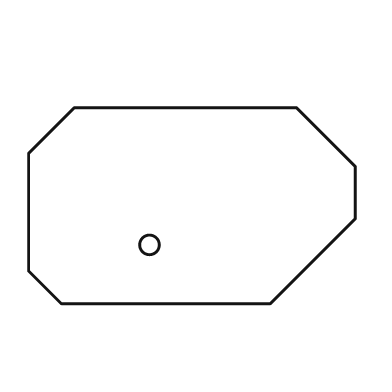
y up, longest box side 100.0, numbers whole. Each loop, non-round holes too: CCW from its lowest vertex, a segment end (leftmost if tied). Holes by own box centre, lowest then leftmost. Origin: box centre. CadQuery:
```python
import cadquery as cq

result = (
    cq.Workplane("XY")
    .moveTo(-40.0, -30.0)
    .lineTo(24.0, -30.0)
    .lineTo(50.0, -4.0)
    .lineTo(50.0, 12.0)
    .lineTo(32.0, 30.0)
    .lineTo(-36.0, 30.0)
    .lineTo(-50.0, 16.0)
    .lineTo(-50.0, -20.0)
    .close()
    .moveTo(-13.0, -12.0)
    .circle(3.0)
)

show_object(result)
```